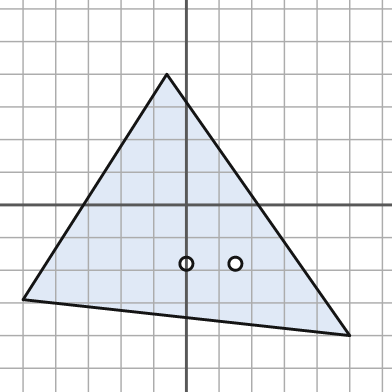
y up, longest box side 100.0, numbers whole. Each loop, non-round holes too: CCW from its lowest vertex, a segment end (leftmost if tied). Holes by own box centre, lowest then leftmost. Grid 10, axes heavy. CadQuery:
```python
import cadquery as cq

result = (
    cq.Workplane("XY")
    .moveTo(50.0, -40.0)
    .lineTo(-6.0, 40.0)
    .lineTo(-50.0, -29.0)
    .close()
    .moveTo(0.0, -18.0)
    .circle(2.0)
    .moveTo(15.0, -18.0)
    .circle(2.0)
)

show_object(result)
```